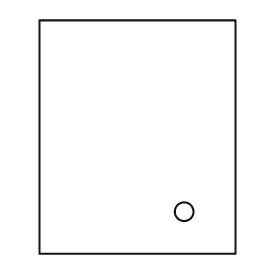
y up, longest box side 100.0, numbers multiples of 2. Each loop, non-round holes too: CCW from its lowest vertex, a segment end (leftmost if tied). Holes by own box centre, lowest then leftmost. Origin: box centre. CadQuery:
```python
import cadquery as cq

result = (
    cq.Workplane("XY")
    .moveTo(-42.0, -50.0)
    .lineTo(42.0, -50.0)
    .lineTo(42.0, 50.0)
    .lineTo(-42.0, 50.0)
    .close()
    .moveTo(20.0, -32.0)
    .circle(4.0)
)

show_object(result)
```